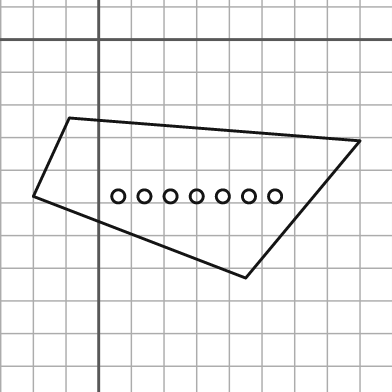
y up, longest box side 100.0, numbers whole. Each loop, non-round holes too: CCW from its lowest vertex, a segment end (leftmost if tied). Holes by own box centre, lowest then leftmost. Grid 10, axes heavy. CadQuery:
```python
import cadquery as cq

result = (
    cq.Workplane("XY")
    .moveTo(45.0, -73.0)
    .lineTo(80.0, -31.0)
    .lineTo(-9.0, -24.0)
    .lineTo(-20.0, -48.0)
    .close()
    .moveTo(6.0, -48.0)
    .circle(2.0)
    .moveTo(14.0, -48.0)
    .circle(2.0)
    .moveTo(22.0, -48.0)
    .circle(2.0)
    .moveTo(30.0, -48.0)
    .circle(2.0)
    .moveTo(38.0, -48.0)
    .circle(2.0)
    .moveTo(46.0, -48.0)
    .circle(2.0)
    .moveTo(54.0, -48.0)
    .circle(2.0)
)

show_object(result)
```